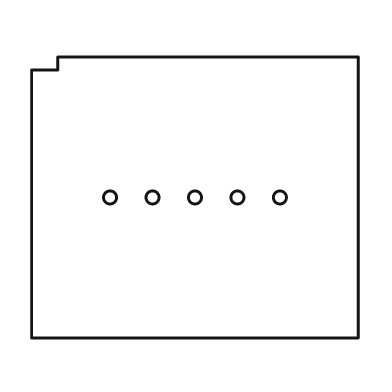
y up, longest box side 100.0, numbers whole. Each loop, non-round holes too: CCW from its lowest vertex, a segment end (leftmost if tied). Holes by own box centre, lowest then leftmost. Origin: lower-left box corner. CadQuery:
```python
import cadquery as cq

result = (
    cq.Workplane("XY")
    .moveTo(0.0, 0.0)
    .lineTo(100.0, 0.0)
    .lineTo(100.0, 86.0)
    .lineTo(8.0, 86.0)
    .lineTo(8.0, 82.0)
    .lineTo(0.0, 82.0)
    .close()
    .moveTo(24.0, 43.0)
    .circle(2.0)
    .moveTo(37.0, 43.0)
    .circle(2.0)
    .moveTo(50.0, 43.0)
    .circle(2.0)
    .moveTo(63.0, 43.0)
    .circle(2.0)
    .moveTo(76.0, 43.0)
    .circle(2.0)
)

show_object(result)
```